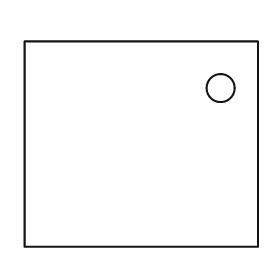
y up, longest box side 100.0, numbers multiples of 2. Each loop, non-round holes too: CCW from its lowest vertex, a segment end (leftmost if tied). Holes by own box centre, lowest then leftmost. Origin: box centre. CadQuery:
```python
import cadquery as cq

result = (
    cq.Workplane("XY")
    .moveTo(-50.0, -44.0)
    .lineTo(50.0, -44.0)
    .lineTo(50.0, 44.0)
    .lineTo(-50.0, 44.0)
    .close()
    .moveTo(34.0, 24.0)
    .circle(6.0)
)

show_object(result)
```